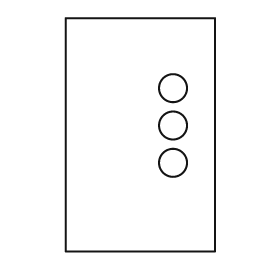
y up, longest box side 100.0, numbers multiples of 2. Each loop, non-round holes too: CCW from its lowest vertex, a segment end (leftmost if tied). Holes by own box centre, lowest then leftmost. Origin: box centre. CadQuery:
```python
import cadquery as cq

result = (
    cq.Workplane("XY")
    .moveTo(-32.0, -50.0)
    .lineTo(32.0, -50.0)
    .lineTo(32.0, 50.0)
    .lineTo(-32.0, 50.0)
    .close()
    .moveTo(14.0, -12.0)
    .circle(6.0)
    .moveTo(14.0, 4.0)
    .circle(6.0)
    .moveTo(14.0, 20.0)
    .circle(6.0)
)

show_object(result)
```